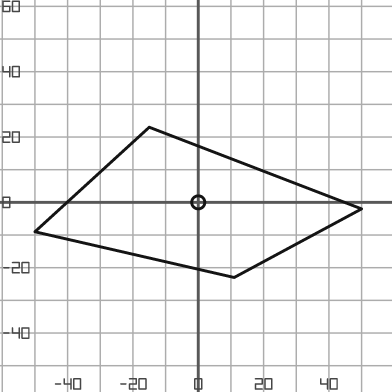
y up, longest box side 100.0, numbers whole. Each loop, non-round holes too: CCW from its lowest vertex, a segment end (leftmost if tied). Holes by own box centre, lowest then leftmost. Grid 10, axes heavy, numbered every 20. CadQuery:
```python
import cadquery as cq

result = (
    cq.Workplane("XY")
    .moveTo(11.0, -23.0)
    .lineTo(50.0, -2.0)
    .lineTo(-15.0, 23.0)
    .lineTo(-50.0, -9.0)
    .close()
    .moveTo(0.0, 0.0)
    .circle(2.0)
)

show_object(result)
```